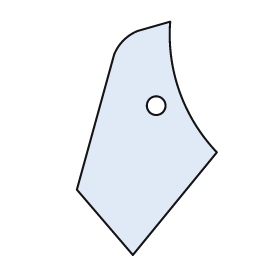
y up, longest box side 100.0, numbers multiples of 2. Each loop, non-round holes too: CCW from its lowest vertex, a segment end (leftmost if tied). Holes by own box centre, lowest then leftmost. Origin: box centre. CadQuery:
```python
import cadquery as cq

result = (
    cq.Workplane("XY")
    .moveTo(-6.0, -50.0)
    .lineTo(30.0, -6.0)
    .threePointArc((14.0, 20.0), (10.0, 50.0))
    .lineTo(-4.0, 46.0)
    .threePointArc((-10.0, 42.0), (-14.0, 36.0))
    .lineTo(-30.0, -22.0)
    .close()
    .moveTo(4.0, 14.0)
    .circle(4.0)
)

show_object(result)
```